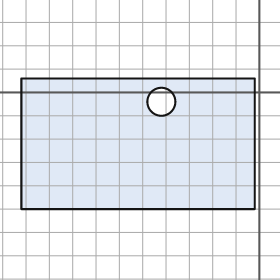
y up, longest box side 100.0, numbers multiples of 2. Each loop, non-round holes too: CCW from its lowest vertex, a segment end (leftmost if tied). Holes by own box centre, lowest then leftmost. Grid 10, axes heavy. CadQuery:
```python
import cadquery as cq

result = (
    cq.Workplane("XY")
    .moveTo(-102.0, -50.0)
    .lineTo(-2.0, -50.0)
    .lineTo(-2.0, 6.0)
    .lineTo(-102.0, 6.0)
    .close()
    .moveTo(-42.0, -4.0)
    .circle(6.0)
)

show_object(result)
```